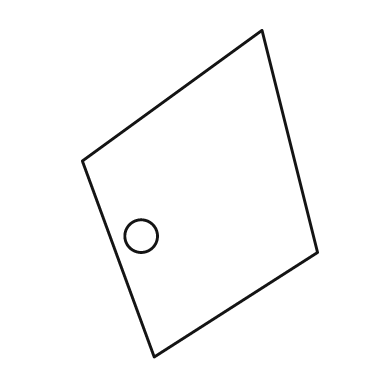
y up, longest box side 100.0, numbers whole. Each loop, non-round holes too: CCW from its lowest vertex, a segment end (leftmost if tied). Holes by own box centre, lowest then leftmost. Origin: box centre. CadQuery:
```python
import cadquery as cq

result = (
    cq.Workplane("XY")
    .moveTo(-14.0, -50.0)
    .lineTo(36.0, -18.0)
    .lineTo(19.0, 50.0)
    .lineTo(-36.0, 10.0)
    .close()
    .moveTo(-18.0, -13.0)
    .circle(5.0)
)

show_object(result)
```